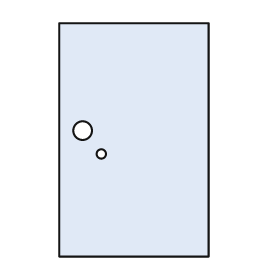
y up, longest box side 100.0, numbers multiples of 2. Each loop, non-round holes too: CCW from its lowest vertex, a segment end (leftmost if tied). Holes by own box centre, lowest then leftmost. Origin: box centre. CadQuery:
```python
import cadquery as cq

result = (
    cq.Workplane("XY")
    .moveTo(-32.0, -50.0)
    .lineTo(32.0, -50.0)
    .lineTo(32.0, 50.0)
    .lineTo(-32.0, 50.0)
    .close()
    .moveTo(-14.0, -6.0)
    .circle(2.0)
    .moveTo(-22.0, 4.0)
    .circle(4.0)
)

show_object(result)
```